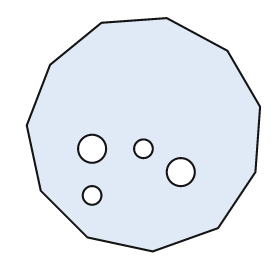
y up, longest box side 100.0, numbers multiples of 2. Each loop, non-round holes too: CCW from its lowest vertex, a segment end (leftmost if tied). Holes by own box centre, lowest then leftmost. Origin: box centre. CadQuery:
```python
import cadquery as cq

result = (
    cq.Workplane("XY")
    .moveTo(4.0, -50.0)
    .lineTo(32.0, -40.0)
    .lineTo(48.0, -16.0)
    .lineTo(50.0, 12.0)
    .lineTo(36.0, 36.0)
    .lineTo(10.0, 50.0)
    .lineTo(-18.0, 48.0)
    .lineTo(-40.0, 30.0)
    .lineTo(-50.0, 4.0)
    .lineTo(-44.0, -24.0)
    .lineTo(-24.0, -44.0)
    .close()
    .moveTo(-22.0, -26.0)
    .circle(4.0)
    .moveTo(16.0, -16.0)
    .circle(6.0)
    .moveTo(-22.0, -6.0)
    .circle(6.0)
    .moveTo(0.0, -6.0)
    .circle(4.0)
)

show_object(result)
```